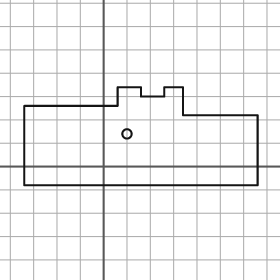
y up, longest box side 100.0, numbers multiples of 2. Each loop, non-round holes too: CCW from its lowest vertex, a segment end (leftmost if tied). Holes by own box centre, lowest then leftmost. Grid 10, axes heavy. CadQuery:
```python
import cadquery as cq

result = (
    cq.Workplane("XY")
    .moveTo(-34.0, -8.0)
    .lineTo(66.0, -8.0)
    .lineTo(66.0, 22.0)
    .lineTo(34.0, 22.0)
    .lineTo(34.0, 34.0)
    .lineTo(26.0, 34.0)
    .lineTo(26.0, 30.0)
    .lineTo(16.0, 30.0)
    .lineTo(16.0, 34.0)
    .lineTo(6.0, 34.0)
    .lineTo(6.0, 26.0)
    .lineTo(-34.0, 26.0)
    .close()
    .moveTo(10.0, 14.0)
    .circle(2.0)
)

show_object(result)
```